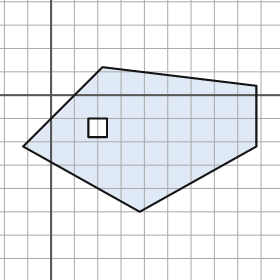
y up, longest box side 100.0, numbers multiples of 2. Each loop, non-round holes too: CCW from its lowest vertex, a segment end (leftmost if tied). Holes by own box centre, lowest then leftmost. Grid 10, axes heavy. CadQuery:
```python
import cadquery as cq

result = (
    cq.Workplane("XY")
    .moveTo(38.0, -50.0)
    .lineTo(88.0, -22.0)
    .lineTo(88.0, 4.0)
    .lineTo(22.0, 12.0)
    .lineTo(-12.0, -22.0)
    .close()
    .moveTo(16.0, -18.0)
    .lineTo(24.0, -18.0)
    .lineTo(24.0, -10.0)
    .lineTo(16.0, -10.0)
    .close()
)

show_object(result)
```